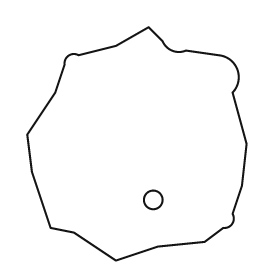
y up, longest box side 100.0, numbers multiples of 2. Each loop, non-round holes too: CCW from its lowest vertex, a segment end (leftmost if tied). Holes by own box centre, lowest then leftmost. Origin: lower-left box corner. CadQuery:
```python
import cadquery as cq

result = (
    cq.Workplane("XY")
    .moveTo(38.0, 0.0)
    .lineTo(56.0, 6.0)
    .lineTo(76.0, 8.0)
    .lineTo(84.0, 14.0)
    .threePointArc((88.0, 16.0), (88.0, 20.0))
    .lineTo(92.0, 32.0)
    .lineTo(94.0, 50.0)
    .lineTo(88.0, 72.0)
    .threePointArc((90.0, 82.0), (82.0, 88.0))
    .lineTo(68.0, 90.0)
    .threePointArc((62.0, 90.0), (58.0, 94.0))
    .lineTo(52.0, 100.0)
    .lineTo(38.0, 92.0)
    .lineTo(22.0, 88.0)
    .threePointArc((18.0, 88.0), (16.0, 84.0))
    .lineTo(12.0, 72.0)
    .lineTo(0.0, 54.0)
    .lineTo(2.0, 38.0)
    .lineTo(10.0, 14.0)
    .lineTo(20.0, 12.0)
    .close()
    .moveTo(54.0, 26.0)
    .circle(4.0)
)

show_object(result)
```